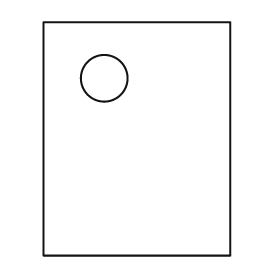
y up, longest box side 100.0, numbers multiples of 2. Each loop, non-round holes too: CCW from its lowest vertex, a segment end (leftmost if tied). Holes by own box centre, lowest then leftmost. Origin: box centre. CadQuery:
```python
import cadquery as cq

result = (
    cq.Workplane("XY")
    .moveTo(-40.0, -50.0)
    .lineTo(40.0, -50.0)
    .lineTo(40.0, 50.0)
    .lineTo(-40.0, 50.0)
    .close()
    .moveTo(-14.0, 26.0)
    .circle(10.0)
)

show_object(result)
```